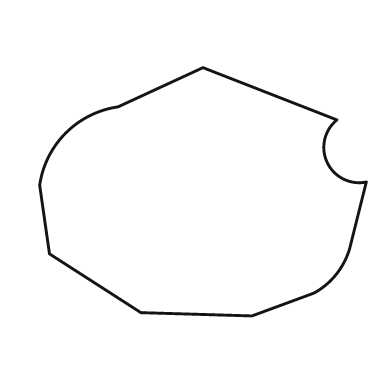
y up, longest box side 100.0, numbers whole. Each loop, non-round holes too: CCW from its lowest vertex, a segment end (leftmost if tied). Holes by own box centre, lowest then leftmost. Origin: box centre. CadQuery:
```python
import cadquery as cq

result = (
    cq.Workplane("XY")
    .moveTo(15.0, -38.0)
    .lineTo(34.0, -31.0)
    .threePointArc((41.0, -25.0), (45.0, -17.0))
    .lineTo(50.0, 3.0)
    .threePointArc((38.0, 9.0), (41.0, 22.0))
    .lineTo(0.0, 38.0)
    .lineTo(-26.0, 26.0)
    .threePointArc((-42.0, 18.0), (-50.0, 2.0))
    .lineTo(-47.0, -19.0)
    .lineTo(-19.0, -37.0)
    .close()
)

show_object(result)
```